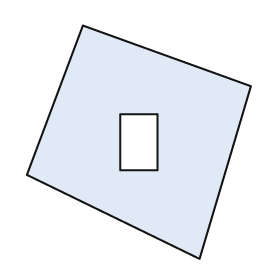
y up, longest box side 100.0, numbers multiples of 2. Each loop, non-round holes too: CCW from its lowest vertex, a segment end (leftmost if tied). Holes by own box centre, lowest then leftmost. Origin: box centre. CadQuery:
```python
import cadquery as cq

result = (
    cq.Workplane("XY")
    .moveTo(26.0, -50.0)
    .lineTo(48.0, 24.0)
    .lineTo(-24.0, 50.0)
    .lineTo(-48.0, -14.0)
    .close()
    .moveTo(-8.0, -12.0)
    .lineTo(8.0, -12.0)
    .lineTo(8.0, 12.0)
    .lineTo(-8.0, 12.0)
    .close()
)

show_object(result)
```